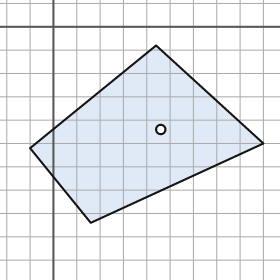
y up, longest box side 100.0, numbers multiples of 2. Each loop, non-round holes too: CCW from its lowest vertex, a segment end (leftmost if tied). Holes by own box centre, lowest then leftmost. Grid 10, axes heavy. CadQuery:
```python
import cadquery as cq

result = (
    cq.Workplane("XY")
    .moveTo(16.0, -84.0)
    .lineTo(90.0, -50.0)
    .lineTo(44.0, -8.0)
    .lineTo(-10.0, -52.0)
    .close()
    .moveTo(46.0, -44.0)
    .circle(2.0)
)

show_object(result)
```